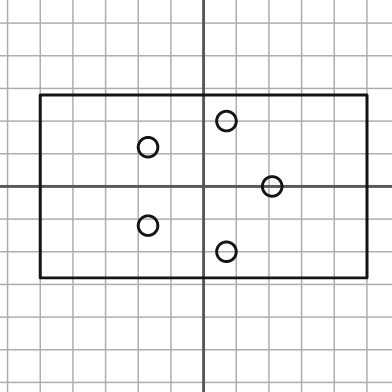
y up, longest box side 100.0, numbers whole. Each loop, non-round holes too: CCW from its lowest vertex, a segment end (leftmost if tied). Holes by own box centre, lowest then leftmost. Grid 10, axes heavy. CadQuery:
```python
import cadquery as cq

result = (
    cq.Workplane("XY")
    .moveTo(-50.0, -28.0)
    .lineTo(50.0, -28.0)
    .lineTo(50.0, 28.0)
    .lineTo(-50.0, 28.0)
    .close()
    .moveTo(7.0, -20.0)
    .circle(3.0)
    .moveTo(-17.0, -12.0)
    .circle(3.0)
    .moveTo(21.0, 0.0)
    .circle(3.0)
    .moveTo(-17.0, 12.0)
    .circle(3.0)
    .moveTo(7.0, 20.0)
    .circle(3.0)
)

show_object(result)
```